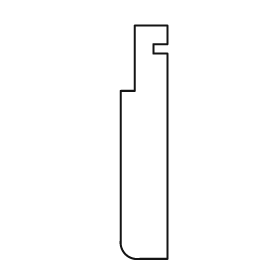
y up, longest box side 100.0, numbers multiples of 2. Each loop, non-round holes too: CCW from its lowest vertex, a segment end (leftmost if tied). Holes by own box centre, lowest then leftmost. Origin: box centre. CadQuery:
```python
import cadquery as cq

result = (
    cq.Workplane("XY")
    .moveTo(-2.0, -50.0)
    .lineTo(10.0, -50.0)
    .lineTo(10.0, 38.0)
    .lineTo(4.0, 38.0)
    .lineTo(4.0, 42.0)
    .lineTo(10.0, 42.0)
    .lineTo(10.0, 50.0)
    .lineTo(-4.0, 50.0)
    .lineTo(-4.0, 22.0)
    .lineTo(-10.0, 22.0)
    .lineTo(-10.0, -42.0)
    .threePointArc((-8.0, -48.0), (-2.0, -50.0))
    .close()
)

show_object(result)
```